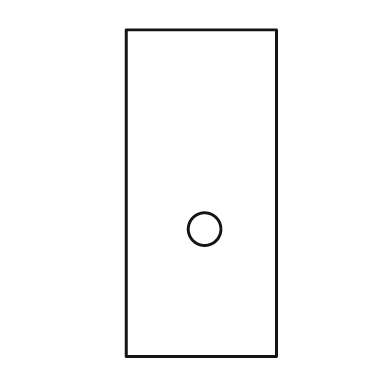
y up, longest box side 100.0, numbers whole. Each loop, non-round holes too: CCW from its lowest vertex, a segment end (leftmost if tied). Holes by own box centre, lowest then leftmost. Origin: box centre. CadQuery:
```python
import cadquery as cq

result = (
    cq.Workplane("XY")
    .moveTo(-23.0, -50.0)
    .lineTo(23.0, -50.0)
    .lineTo(23.0, 50.0)
    .lineTo(-23.0, 50.0)
    .close()
    .moveTo(1.0, -11.0)
    .circle(5.0)
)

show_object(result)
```